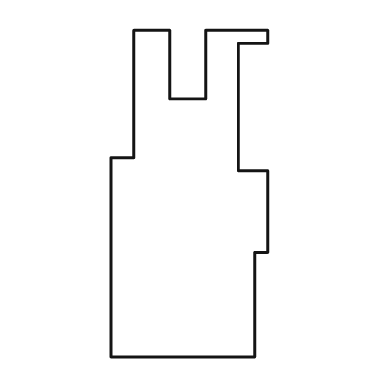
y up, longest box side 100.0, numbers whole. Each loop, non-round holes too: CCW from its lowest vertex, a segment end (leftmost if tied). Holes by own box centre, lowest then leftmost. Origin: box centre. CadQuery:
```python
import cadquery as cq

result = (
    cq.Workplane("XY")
    .moveTo(-24.0, -50.0)
    .lineTo(20.0, -50.0)
    .lineTo(20.0, -18.0)
    .lineTo(24.0, -18.0)
    .lineTo(24.0, 7.0)
    .lineTo(15.0, 7.0)
    .lineTo(15.0, 46.0)
    .lineTo(24.0, 46.0)
    .lineTo(24.0, 50.0)
    .lineTo(5.0, 50.0)
    .lineTo(5.0, 29.0)
    .lineTo(-6.0, 29.0)
    .lineTo(-6.0, 50.0)
    .lineTo(-17.0, 50.0)
    .lineTo(-17.0, 11.0)
    .lineTo(-24.0, 11.0)
    .close()
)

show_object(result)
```